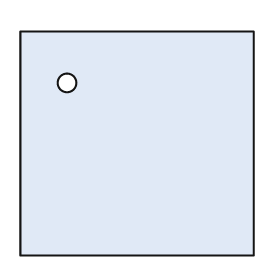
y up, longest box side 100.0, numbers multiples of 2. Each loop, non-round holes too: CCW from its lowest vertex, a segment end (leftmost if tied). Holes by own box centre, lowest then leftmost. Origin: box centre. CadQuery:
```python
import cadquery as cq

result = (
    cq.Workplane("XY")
    .moveTo(-50.0, -48.0)
    .lineTo(50.0, -48.0)
    .lineTo(50.0, 48.0)
    .lineTo(-50.0, 48.0)
    .close()
    .moveTo(-30.0, 26.0)
    .circle(4.0)
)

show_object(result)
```